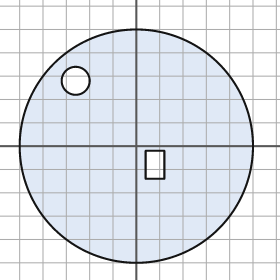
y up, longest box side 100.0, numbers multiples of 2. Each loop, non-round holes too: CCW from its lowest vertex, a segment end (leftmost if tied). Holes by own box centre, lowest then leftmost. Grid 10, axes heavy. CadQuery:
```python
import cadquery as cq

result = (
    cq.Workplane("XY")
    .moveTo(0.0, 0.0)
    .circle(50.0)
    .moveTo(4.0, -14.0)
    .lineTo(12.0, -14.0)
    .lineTo(12.0, -2.0)
    .lineTo(4.0, -2.0)
    .close()
    .moveTo(-26.0, 28.0)
    .circle(6.0)
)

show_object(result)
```